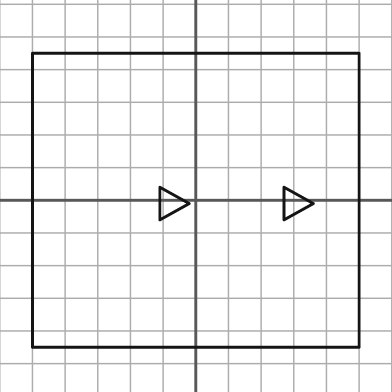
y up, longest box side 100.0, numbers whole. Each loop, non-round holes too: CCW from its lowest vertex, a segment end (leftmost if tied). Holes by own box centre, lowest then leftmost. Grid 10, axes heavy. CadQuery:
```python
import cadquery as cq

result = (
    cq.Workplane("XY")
    .moveTo(-50.0, -45.0)
    .lineTo(50.0, -45.0)
    .lineTo(50.0, 45.0)
    .lineTo(-50.0, 45.0)
    .close()
    .moveTo(-11.0, -6.0)
    .lineTo(-2.0, -1.0)
    .lineTo(-11.0, 4.0)
    .close()
    .moveTo(27.0, -6.0)
    .lineTo(36.0, -1.0)
    .lineTo(27.0, 4.0)
    .close()
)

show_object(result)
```